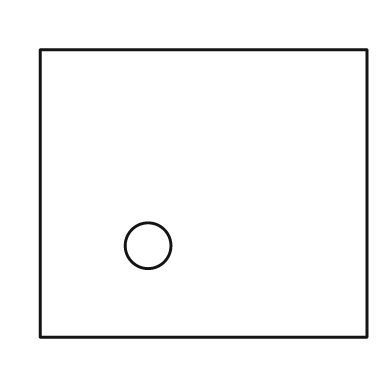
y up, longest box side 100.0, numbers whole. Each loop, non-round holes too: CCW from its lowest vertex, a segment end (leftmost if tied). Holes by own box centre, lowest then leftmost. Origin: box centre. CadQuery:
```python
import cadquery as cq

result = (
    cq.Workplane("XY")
    .moveTo(-50.0, -44.0)
    .lineTo(50.0, -44.0)
    .lineTo(50.0, 44.0)
    .lineTo(-50.0, 44.0)
    .close()
    .moveTo(-17.0, -16.0)
    .circle(7.0)
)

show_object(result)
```